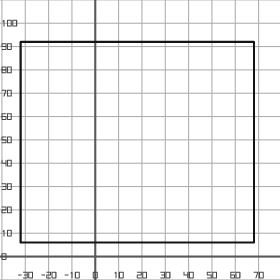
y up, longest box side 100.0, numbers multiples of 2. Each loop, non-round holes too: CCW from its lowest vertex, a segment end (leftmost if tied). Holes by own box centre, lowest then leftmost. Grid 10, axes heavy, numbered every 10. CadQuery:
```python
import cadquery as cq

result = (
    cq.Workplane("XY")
    .moveTo(-32.0, 6.0)
    .lineTo(68.0, 6.0)
    .lineTo(68.0, 92.0)
    .lineTo(-32.0, 92.0)
    .close()
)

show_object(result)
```